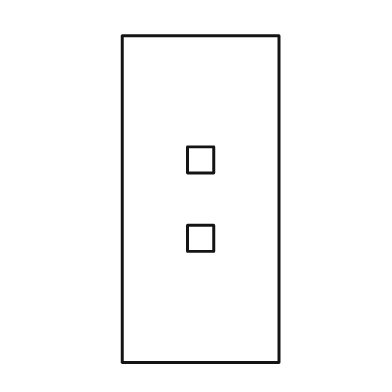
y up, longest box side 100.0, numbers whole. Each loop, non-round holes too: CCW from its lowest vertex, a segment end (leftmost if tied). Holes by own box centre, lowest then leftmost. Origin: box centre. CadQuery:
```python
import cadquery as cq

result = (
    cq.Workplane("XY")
    .moveTo(-24.0, -50.0)
    .lineTo(24.0, -50.0)
    .lineTo(24.0, 50.0)
    .lineTo(-24.0, 50.0)
    .close()
    .moveTo(-4.0, -16.0)
    .lineTo(4.0, -16.0)
    .lineTo(4.0, -8.0)
    .lineTo(-4.0, -8.0)
    .close()
    .moveTo(-4.0, 8.0)
    .lineTo(4.0, 8.0)
    .lineTo(4.0, 16.0)
    .lineTo(-4.0, 16.0)
    .close()
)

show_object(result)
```